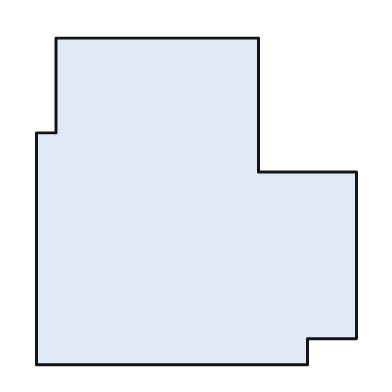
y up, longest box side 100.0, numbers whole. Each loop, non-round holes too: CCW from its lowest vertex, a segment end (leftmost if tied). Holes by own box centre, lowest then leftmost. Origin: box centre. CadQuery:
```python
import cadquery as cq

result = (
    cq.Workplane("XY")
    .moveTo(-49.0, -50.0)
    .lineTo(34.0, -50.0)
    .lineTo(34.0, -42.0)
    .lineTo(49.0, -42.0)
    .lineTo(49.0, 9.0)
    .lineTo(19.0, 9.0)
    .lineTo(19.0, 50.0)
    .lineTo(-43.0, 50.0)
    .lineTo(-43.0, 21.0)
    .lineTo(-49.0, 21.0)
    .close()
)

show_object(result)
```